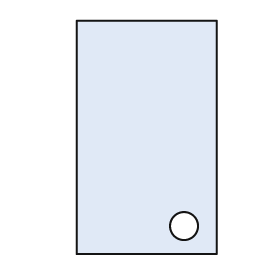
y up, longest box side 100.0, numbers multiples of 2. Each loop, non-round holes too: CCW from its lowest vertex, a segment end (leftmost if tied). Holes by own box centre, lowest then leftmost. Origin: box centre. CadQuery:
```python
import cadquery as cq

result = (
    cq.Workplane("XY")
    .moveTo(-30.0, -50.0)
    .lineTo(30.0, -50.0)
    .lineTo(30.0, 50.0)
    .lineTo(-30.0, 50.0)
    .close()
    .moveTo(16.0, -38.0)
    .circle(6.0)
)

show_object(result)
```